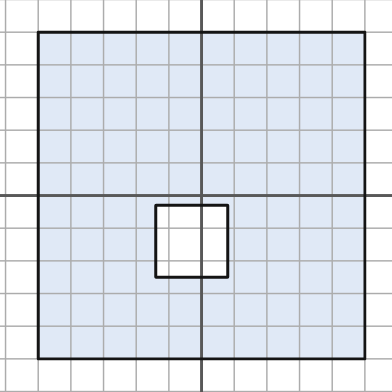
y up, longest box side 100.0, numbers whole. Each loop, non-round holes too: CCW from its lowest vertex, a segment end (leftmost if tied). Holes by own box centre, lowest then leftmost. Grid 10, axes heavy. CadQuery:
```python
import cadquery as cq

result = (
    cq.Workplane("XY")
    .moveTo(-50.0, -50.0)
    .lineTo(50.0, -50.0)
    .lineTo(50.0, 50.0)
    .lineTo(-50.0, 50.0)
    .close()
    .moveTo(-14.0, -25.0)
    .lineTo(8.0, -25.0)
    .lineTo(8.0, -3.0)
    .lineTo(-14.0, -3.0)
    .close()
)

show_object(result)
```